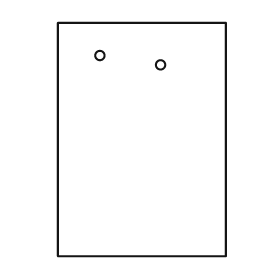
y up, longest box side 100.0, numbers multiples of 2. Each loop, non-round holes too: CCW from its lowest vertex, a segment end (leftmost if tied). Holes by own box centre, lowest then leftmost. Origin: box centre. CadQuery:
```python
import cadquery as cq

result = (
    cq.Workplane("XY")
    .moveTo(-36.0, -50.0)
    .lineTo(36.0, -50.0)
    .lineTo(36.0, 50.0)
    .lineTo(-36.0, 50.0)
    .close()
    .moveTo(8.0, 32.0)
    .circle(2.0)
    .moveTo(-18.0, 36.0)
    .circle(2.0)
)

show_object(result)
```